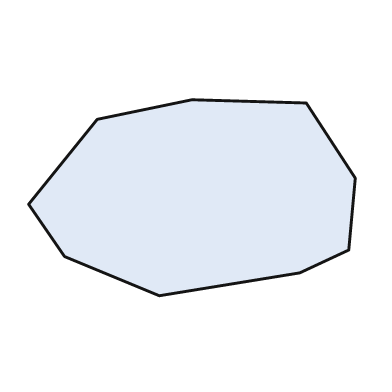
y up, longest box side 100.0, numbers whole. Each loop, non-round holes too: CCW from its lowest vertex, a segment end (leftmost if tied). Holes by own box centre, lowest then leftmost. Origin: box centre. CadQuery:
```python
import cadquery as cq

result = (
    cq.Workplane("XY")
    .moveTo(-10.0, -30.0)
    .lineTo(33.0, -23.0)
    .lineTo(48.0, -16.0)
    .lineTo(50.0, 6.0)
    .lineTo(35.0, 29.0)
    .lineTo(0.0, 30.0)
    .lineTo(-29.0, 24.0)
    .lineTo(-50.0, -2.0)
    .lineTo(-39.0, -18.0)
    .close()
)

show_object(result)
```